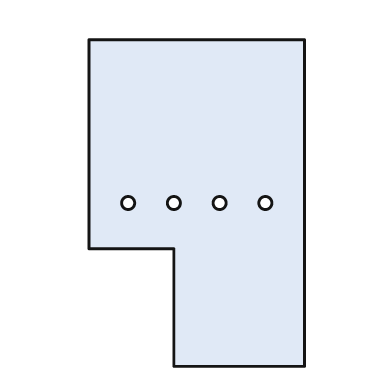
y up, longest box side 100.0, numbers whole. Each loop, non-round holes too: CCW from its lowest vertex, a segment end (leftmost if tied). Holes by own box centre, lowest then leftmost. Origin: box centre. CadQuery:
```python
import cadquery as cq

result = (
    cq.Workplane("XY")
    .moveTo(-7.0, -50.0)
    .lineTo(33.0, -50.0)
    .lineTo(33.0, 50.0)
    .lineTo(-33.0, 50.0)
    .lineTo(-33.0, -14.0)
    .lineTo(-7.0, -14.0)
    .close()
    .moveTo(-21.0, 0.0)
    .circle(2.0)
    .moveTo(-7.0, 0.0)
    .circle(2.0)
    .moveTo(7.0, 0.0)
    .circle(2.0)
    .moveTo(21.0, 0.0)
    .circle(2.0)
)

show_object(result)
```